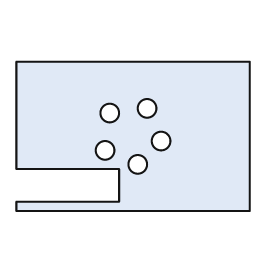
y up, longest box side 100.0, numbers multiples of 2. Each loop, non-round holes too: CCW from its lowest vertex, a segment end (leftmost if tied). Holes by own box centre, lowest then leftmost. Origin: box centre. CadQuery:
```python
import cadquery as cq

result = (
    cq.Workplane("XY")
    .moveTo(-50.0, -32.0)
    .lineTo(50.0, -32.0)
    .lineTo(50.0, 32.0)
    .lineTo(-50.0, 32.0)
    .lineTo(-50.0, -14.0)
    .lineTo(-6.0, -14.0)
    .lineTo(-6.0, -28.0)
    .lineTo(-50.0, -28.0)
    .close()
    .moveTo(2.0, -12.0)
    .circle(4.0)
    .moveTo(-12.0, -6.0)
    .circle(4.0)
    .moveTo(12.0, -2.0)
    .circle(4.0)
    .moveTo(-10.0, 10.0)
    .circle(4.0)
    .moveTo(6.0, 12.0)
    .circle(4.0)
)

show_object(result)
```